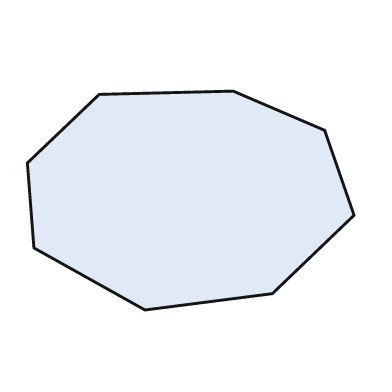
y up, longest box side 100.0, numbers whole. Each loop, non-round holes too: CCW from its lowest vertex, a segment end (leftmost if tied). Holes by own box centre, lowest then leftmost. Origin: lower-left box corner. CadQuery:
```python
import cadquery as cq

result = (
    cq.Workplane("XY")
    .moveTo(36.0, 0.0)
    .lineTo(75.0, 5.0)
    .lineTo(100.0, 29.0)
    .lineTo(91.0, 55.0)
    .lineTo(63.0, 67.0)
    .lineTo(22.0, 66.0)
    .lineTo(0.0, 45.0)
    .lineTo(2.0, 19.0)
    .close()
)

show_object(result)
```